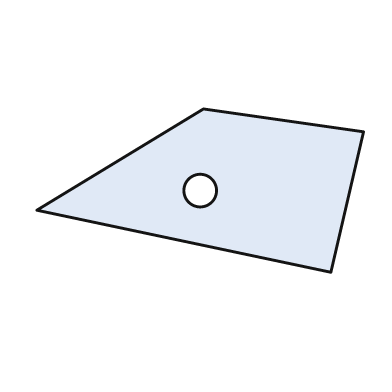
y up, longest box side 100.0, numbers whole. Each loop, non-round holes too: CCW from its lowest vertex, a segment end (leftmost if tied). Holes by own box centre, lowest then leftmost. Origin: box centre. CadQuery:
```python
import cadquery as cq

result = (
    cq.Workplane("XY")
    .moveTo(40.0, -25.0)
    .lineTo(50.0, 18.0)
    .lineTo(1.0, 25.0)
    .lineTo(-50.0, -6.0)
    .close()
    .moveTo(0.0, 0.0)
    .circle(5.0)
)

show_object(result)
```